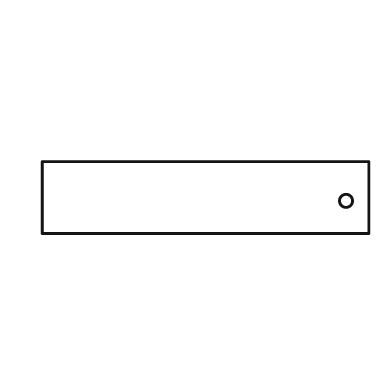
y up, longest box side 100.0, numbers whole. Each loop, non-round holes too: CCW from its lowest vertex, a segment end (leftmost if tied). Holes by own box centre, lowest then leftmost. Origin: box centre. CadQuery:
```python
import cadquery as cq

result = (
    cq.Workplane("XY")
    .moveTo(-50.0, -11.0)
    .lineTo(50.0, -11.0)
    .lineTo(50.0, 11.0)
    .lineTo(-50.0, 11.0)
    .close()
    .moveTo(43.0, -1.0)
    .circle(2.0)
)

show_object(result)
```